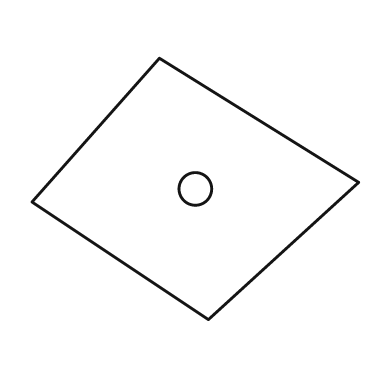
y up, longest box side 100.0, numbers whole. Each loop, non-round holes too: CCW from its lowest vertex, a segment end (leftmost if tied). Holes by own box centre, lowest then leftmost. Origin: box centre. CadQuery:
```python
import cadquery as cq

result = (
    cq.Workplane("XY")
    .moveTo(4.0, -40.0)
    .lineTo(50.0, 2.0)
    .lineTo(-11.0, 40.0)
    .lineTo(-50.0, -4.0)
    .close()
    .moveTo(0.0, 0.0)
    .circle(5.0)
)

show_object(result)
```